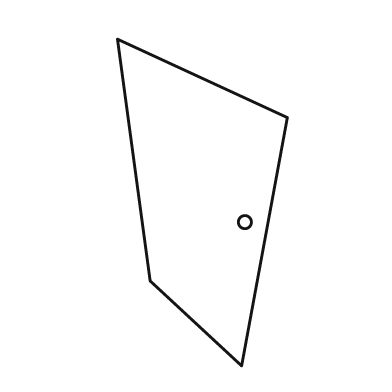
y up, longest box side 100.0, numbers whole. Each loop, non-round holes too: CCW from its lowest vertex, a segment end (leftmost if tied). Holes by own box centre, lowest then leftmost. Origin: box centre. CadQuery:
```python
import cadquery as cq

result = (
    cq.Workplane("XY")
    .moveTo(12.0, -50.0)
    .lineTo(26.0, 26.0)
    .lineTo(-26.0, 50.0)
    .lineTo(-16.0, -24.0)
    .close()
    .moveTo(13.0, -6.0)
    .circle(2.0)
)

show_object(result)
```